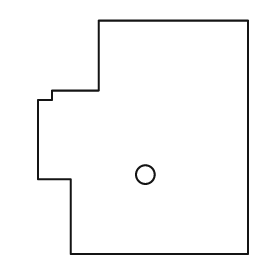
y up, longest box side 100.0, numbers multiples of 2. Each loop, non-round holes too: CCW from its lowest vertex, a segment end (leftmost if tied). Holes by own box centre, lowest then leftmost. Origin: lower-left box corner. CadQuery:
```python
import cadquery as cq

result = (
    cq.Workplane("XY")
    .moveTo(14.0, 0.0)
    .lineTo(90.0, 0.0)
    .lineTo(90.0, 100.0)
    .lineTo(26.0, 100.0)
    .lineTo(26.0, 70.0)
    .lineTo(6.0, 70.0)
    .lineTo(6.0, 66.0)
    .lineTo(0.0, 66.0)
    .lineTo(0.0, 32.0)
    .lineTo(14.0, 32.0)
    .close()
    .moveTo(46.0, 34.0)
    .circle(4.0)
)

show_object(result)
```